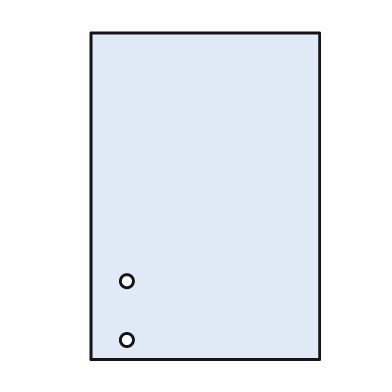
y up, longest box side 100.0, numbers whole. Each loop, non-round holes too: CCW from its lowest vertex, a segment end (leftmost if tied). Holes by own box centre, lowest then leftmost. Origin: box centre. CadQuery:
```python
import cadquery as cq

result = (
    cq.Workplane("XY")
    .moveTo(-35.0, -50.0)
    .lineTo(35.0, -50.0)
    .lineTo(35.0, 50.0)
    .lineTo(-35.0, 50.0)
    .close()
    .moveTo(-24.0, -44.0)
    .circle(2.0)
    .moveTo(-24.0, -26.0)
    .circle(2.0)
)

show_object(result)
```